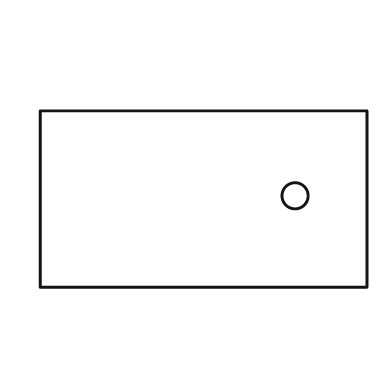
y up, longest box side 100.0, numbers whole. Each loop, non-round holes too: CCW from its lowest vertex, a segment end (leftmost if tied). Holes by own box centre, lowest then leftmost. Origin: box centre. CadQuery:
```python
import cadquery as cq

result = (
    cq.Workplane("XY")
    .moveTo(-50.0, -27.0)
    .lineTo(50.0, -27.0)
    .lineTo(50.0, 27.0)
    .lineTo(-50.0, 27.0)
    .close()
    .moveTo(28.0, 1.0)
    .circle(4.0)
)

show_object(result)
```